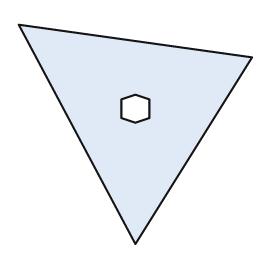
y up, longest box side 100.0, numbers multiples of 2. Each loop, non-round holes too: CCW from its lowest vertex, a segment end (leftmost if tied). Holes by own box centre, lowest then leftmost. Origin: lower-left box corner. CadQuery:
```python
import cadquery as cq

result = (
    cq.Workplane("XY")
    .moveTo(50.0, 0.0)
    .lineTo(100.0, 80.0)
    .lineTo(0.0, 94.0)
    .close()
    .moveTo(50.0, 52.0)
    .lineTo(56.0, 54.0)
    .lineTo(56.0, 62.0)
    .lineTo(50.0, 64.0)
    .lineTo(44.0, 62.0)
    .lineTo(44.0, 54.0)
    .close()
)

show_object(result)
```